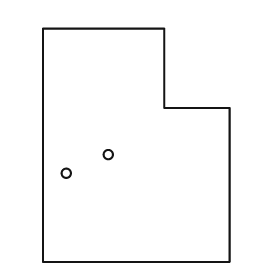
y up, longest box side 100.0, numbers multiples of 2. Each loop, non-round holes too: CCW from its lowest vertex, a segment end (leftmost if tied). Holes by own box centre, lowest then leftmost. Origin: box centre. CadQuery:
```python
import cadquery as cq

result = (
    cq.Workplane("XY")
    .moveTo(-40.0, -50.0)
    .lineTo(40.0, -50.0)
    .lineTo(40.0, 16.0)
    .lineTo(12.0, 16.0)
    .lineTo(12.0, 50.0)
    .lineTo(-40.0, 50.0)
    .close()
    .moveTo(-30.0, -12.0)
    .circle(2.0)
    .moveTo(-12.0, -4.0)
    .circle(2.0)
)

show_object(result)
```